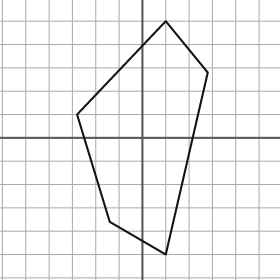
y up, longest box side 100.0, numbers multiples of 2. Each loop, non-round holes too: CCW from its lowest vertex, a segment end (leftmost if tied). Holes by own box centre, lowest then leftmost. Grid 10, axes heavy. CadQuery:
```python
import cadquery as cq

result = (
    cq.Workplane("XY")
    .moveTo(10.0, -50.0)
    .lineTo(28.0, 28.0)
    .lineTo(10.0, 50.0)
    .lineTo(-28.0, 10.0)
    .lineTo(-14.0, -36.0)
    .close()
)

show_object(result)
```